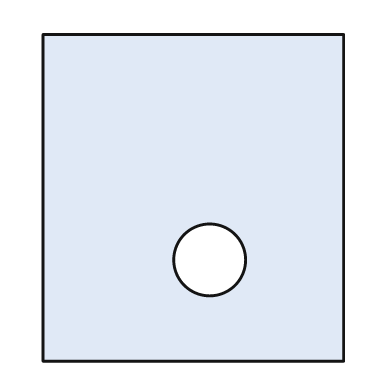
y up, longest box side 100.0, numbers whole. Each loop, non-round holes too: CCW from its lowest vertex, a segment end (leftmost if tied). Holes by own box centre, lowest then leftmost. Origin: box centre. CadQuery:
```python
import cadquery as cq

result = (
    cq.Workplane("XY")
    .moveTo(-46.0, -50.0)
    .lineTo(46.0, -50.0)
    .lineTo(46.0, 50.0)
    .lineTo(-46.0, 50.0)
    .close()
    .moveTo(5.0, -19.0)
    .circle(11.0)
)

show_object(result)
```